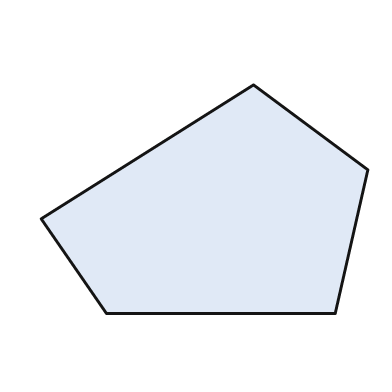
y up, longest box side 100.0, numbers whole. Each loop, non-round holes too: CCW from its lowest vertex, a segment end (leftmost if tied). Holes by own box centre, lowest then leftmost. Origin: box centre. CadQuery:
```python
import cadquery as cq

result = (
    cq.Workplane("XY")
    .moveTo(-30.0, -35.0)
    .lineTo(40.0, -35.0)
    .lineTo(50.0, 9.0)
    .lineTo(15.0, 35.0)
    .lineTo(-50.0, -6.0)
    .close()
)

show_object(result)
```